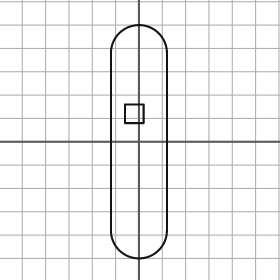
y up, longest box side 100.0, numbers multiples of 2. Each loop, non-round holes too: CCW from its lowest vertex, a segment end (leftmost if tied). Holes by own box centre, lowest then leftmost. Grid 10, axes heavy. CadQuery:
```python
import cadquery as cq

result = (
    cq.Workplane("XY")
    .moveTo(-12.0, -38.0)
    .threePointArc((0.0, -50.0), (12.0, -38.0))
    .lineTo(12.0, 38.0)
    .threePointArc((0.0, 50.0), (-12.0, 38.0))
    .close()
    .moveTo(-6.0, 8.0)
    .lineTo(2.0, 8.0)
    .lineTo(2.0, 16.0)
    .lineTo(-6.0, 16.0)
    .close()
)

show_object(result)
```